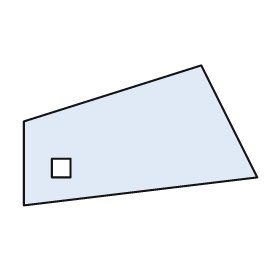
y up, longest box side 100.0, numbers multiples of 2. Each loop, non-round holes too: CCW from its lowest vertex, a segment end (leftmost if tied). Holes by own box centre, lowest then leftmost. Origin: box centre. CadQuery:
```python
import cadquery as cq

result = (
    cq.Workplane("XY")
    .moveTo(-50.0, -30.0)
    .lineTo(50.0, -18.0)
    .lineTo(26.0, 30.0)
    .lineTo(-50.0, 6.0)
    .close()
    .moveTo(-38.0, -18.0)
    .lineTo(-30.0, -18.0)
    .lineTo(-30.0, -10.0)
    .lineTo(-38.0, -10.0)
    .close()
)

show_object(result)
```